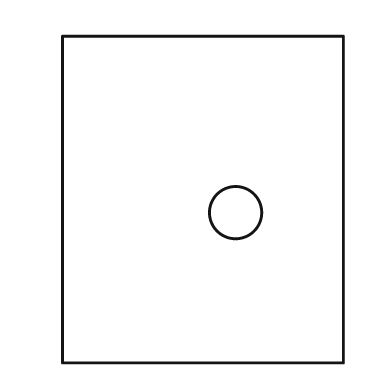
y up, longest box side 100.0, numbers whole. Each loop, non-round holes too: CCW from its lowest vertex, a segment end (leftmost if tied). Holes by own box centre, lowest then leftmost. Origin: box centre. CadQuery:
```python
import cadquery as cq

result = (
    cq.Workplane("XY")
    .moveTo(-43.0, -50.0)
    .lineTo(43.0, -50.0)
    .lineTo(43.0, 50.0)
    .lineTo(-43.0, 50.0)
    .close()
    .moveTo(10.0, -4.0)
    .circle(8.0)
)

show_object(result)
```